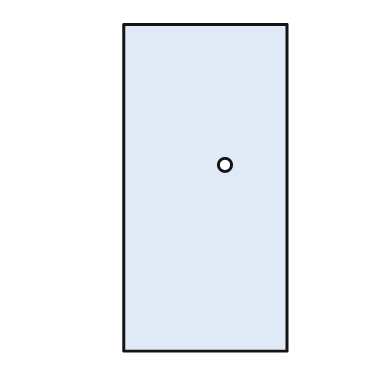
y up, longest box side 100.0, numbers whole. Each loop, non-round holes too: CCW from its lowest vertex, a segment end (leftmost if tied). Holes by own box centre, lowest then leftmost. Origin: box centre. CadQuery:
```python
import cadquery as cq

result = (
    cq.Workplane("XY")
    .moveTo(-25.0, -50.0)
    .lineTo(25.0, -50.0)
    .lineTo(25.0, 50.0)
    .lineTo(-25.0, 50.0)
    .close()
    .moveTo(6.0, 7.0)
    .circle(2.0)
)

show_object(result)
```